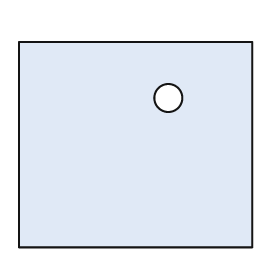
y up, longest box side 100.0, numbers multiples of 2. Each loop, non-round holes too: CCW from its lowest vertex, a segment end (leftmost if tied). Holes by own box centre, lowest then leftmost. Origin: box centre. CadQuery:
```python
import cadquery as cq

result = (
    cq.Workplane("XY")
    .moveTo(-50.0, -44.0)
    .lineTo(50.0, -44.0)
    .lineTo(50.0, 44.0)
    .lineTo(-50.0, 44.0)
    .close()
    .moveTo(14.0, 20.0)
    .circle(6.0)
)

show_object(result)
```